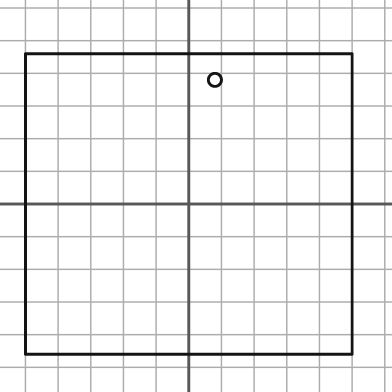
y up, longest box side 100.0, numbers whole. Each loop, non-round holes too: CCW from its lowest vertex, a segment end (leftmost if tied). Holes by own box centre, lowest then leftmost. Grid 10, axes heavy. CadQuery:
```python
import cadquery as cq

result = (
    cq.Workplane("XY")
    .moveTo(-50.0, -46.0)
    .lineTo(50.0, -46.0)
    .lineTo(50.0, 46.0)
    .lineTo(-50.0, 46.0)
    .close()
    .moveTo(8.0, 38.0)
    .circle(2.0)
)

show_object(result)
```